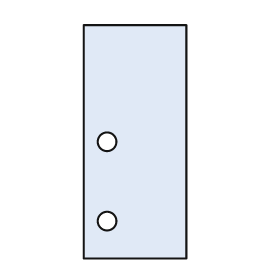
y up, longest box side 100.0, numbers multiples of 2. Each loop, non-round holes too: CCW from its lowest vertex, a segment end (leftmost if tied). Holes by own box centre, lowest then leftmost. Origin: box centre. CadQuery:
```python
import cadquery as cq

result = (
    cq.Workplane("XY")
    .moveTo(-22.0, -50.0)
    .lineTo(22.0, -50.0)
    .lineTo(22.0, 50.0)
    .lineTo(-22.0, 50.0)
    .close()
    .moveTo(-12.0, -34.0)
    .circle(4.0)
    .moveTo(-12.0, 0.0)
    .circle(4.0)
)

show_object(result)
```